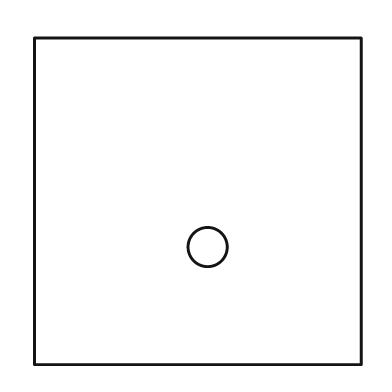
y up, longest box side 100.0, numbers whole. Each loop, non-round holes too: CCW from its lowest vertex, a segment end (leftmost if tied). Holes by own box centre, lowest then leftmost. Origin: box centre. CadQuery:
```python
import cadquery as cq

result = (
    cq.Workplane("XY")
    .moveTo(-50.0, -50.0)
    .lineTo(50.0, -50.0)
    .lineTo(50.0, 50.0)
    .lineTo(-50.0, 50.0)
    .close()
    .moveTo(3.0, -14.0)
    .circle(6.0)
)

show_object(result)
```